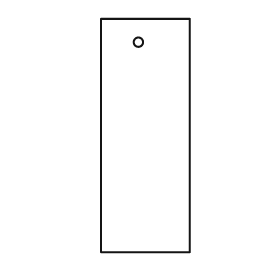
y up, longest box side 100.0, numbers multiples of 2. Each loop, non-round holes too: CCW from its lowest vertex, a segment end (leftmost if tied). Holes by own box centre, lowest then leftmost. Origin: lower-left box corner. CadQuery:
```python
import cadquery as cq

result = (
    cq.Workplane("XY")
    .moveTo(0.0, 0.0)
    .lineTo(38.0, 0.0)
    .lineTo(38.0, 100.0)
    .lineTo(0.0, 100.0)
    .close()
    .moveTo(16.0, 90.0)
    .circle(2.0)
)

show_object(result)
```